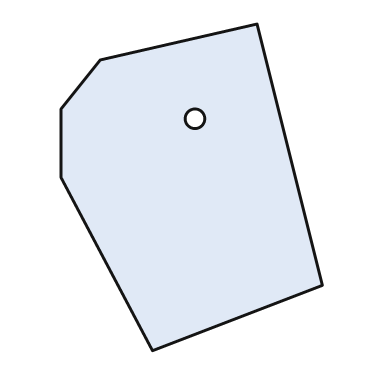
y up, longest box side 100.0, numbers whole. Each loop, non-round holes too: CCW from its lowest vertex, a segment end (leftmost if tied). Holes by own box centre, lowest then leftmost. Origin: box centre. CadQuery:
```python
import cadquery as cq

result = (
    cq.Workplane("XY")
    .moveTo(-12.0, -50.0)
    .lineTo(40.0, -30.0)
    .lineTo(20.0, 50.0)
    .lineTo(-28.0, 39.0)
    .lineTo(-40.0, 24.0)
    .lineTo(-40.0, 3.0)
    .close()
    .moveTo(1.0, 21.0)
    .circle(3.0)
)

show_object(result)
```